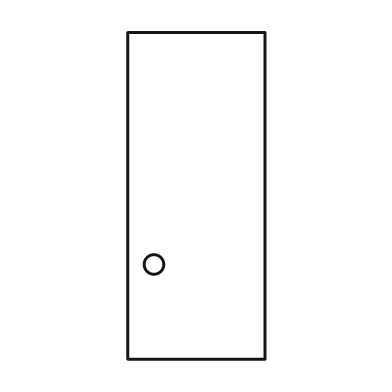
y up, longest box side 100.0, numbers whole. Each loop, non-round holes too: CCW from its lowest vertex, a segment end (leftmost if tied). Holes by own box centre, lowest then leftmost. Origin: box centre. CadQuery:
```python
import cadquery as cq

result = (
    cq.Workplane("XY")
    .moveTo(-21.0, -50.0)
    .lineTo(21.0, -50.0)
    .lineTo(21.0, 50.0)
    .lineTo(-21.0, 50.0)
    .close()
    .moveTo(-13.0, -21.0)
    .circle(3.0)
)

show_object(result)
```